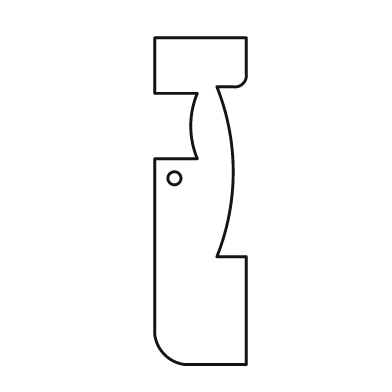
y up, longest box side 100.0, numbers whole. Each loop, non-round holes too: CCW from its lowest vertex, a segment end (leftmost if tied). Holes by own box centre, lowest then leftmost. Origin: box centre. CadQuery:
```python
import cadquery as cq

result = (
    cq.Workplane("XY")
    .moveTo(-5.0, -50.0)
    .lineTo(14.0, -50.0)
    .lineTo(14.0, -17.0)
    .lineTo(5.0, -17.0)
    .threePointArc((10.0, 9.0), (5.0, 35.0))
    .lineTo(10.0, 35.0)
    .threePointArc((13.0, 36.0), (14.0, 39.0))
    .lineTo(14.0, 50.0)
    .lineTo(-14.0, 50.0)
    .lineTo(-14.0, 33.0)
    .lineTo(-1.0, 33.0)
    .threePointArc((-3.0, 23.0), (-1.0, 13.0))
    .lineTo(-14.0, 13.0)
    .lineTo(-14.0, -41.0)
    .threePointArc((-11.0, -47.0), (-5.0, -50.0))
    .close()
    .moveTo(-8.0, 7.0)
    .circle(2.0)
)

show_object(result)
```